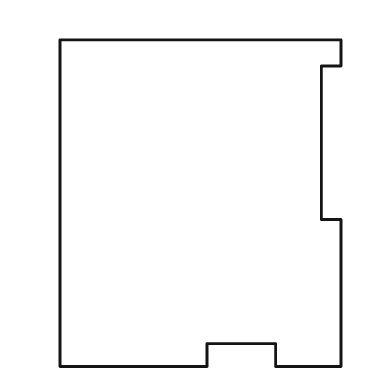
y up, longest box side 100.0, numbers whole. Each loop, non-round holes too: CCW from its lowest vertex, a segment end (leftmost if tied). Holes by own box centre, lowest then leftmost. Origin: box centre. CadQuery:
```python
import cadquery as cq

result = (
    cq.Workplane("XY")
    .moveTo(-43.0, -50.0)
    .lineTo(2.0, -50.0)
    .lineTo(2.0, -43.0)
    .lineTo(23.0, -43.0)
    .lineTo(23.0, -50.0)
    .lineTo(43.0, -50.0)
    .lineTo(43.0, -5.0)
    .lineTo(37.0, -5.0)
    .lineTo(37.0, 42.0)
    .lineTo(43.0, 42.0)
    .lineTo(43.0, 50.0)
    .lineTo(-43.0, 50.0)
    .close()
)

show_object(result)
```